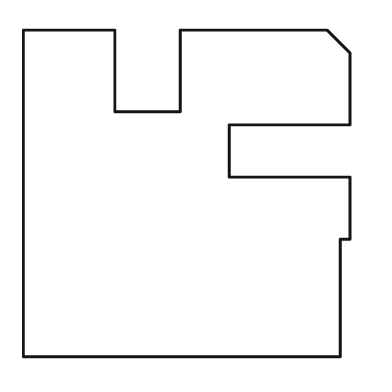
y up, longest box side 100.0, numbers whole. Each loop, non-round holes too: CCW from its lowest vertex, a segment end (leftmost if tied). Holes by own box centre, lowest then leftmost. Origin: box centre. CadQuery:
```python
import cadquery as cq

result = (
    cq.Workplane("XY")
    .moveTo(-50.0, -50.0)
    .lineTo(47.0, -50.0)
    .lineTo(47.0, -14.0)
    .lineTo(50.0, -14.0)
    .lineTo(50.0, 5.0)
    .lineTo(13.0, 5.0)
    .lineTo(13.0, 21.0)
    .lineTo(50.0, 21.0)
    .lineTo(50.0, 43.0)
    .lineTo(43.0, 50.0)
    .lineTo(-2.0, 50.0)
    .lineTo(-2.0, 25.0)
    .lineTo(-22.0, 25.0)
    .lineTo(-22.0, 50.0)
    .lineTo(-50.0, 50.0)
    .close()
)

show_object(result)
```